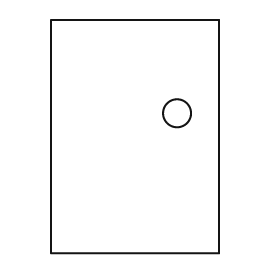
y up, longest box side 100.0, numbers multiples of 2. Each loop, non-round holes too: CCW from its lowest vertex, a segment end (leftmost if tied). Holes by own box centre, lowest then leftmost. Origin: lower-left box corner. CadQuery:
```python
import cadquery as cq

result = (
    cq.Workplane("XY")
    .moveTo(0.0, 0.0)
    .lineTo(72.0, 0.0)
    .lineTo(72.0, 100.0)
    .lineTo(0.0, 100.0)
    .close()
    .moveTo(54.0, 60.0)
    .circle(6.0)
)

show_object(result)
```